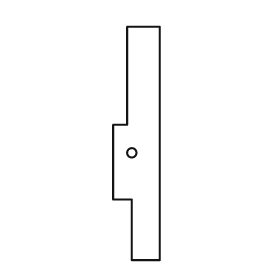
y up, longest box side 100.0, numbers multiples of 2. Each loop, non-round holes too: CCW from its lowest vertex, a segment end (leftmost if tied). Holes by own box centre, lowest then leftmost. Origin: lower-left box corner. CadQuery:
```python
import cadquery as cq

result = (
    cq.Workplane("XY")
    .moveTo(8.0, 0.0)
    .lineTo(20.0, 0.0)
    .lineTo(20.0, 100.0)
    .lineTo(6.0, 100.0)
    .lineTo(6.0, 58.0)
    .lineTo(0.0, 58.0)
    .lineTo(0.0, 26.0)
    .lineTo(8.0, 26.0)
    .close()
    .moveTo(8.0, 46.0)
    .circle(2.0)
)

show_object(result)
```